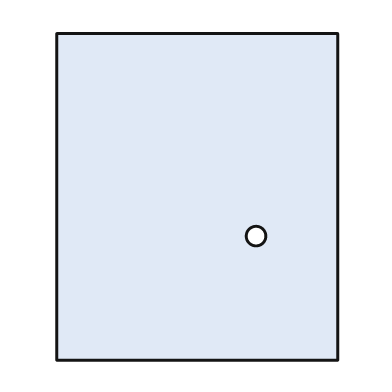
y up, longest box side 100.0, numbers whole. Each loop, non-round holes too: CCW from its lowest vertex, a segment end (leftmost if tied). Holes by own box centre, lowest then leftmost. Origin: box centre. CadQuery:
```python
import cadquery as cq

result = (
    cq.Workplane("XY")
    .moveTo(-43.0, -50.0)
    .lineTo(43.0, -50.0)
    .lineTo(43.0, 50.0)
    .lineTo(-43.0, 50.0)
    .close()
    .moveTo(18.0, -12.0)
    .circle(3.0)
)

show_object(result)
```